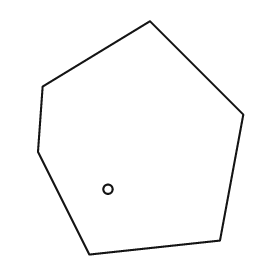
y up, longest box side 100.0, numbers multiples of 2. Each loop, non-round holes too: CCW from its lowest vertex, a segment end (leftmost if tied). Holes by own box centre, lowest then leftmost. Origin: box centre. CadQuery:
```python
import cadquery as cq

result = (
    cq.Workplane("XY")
    .moveTo(-22.0, -50.0)
    .lineTo(34.0, -44.0)
    .lineTo(44.0, 10.0)
    .lineTo(4.0, 50.0)
    .lineTo(-42.0, 22.0)
    .lineTo(-44.0, -6.0)
    .close()
    .moveTo(-14.0, -22.0)
    .circle(2.0)
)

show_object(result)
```